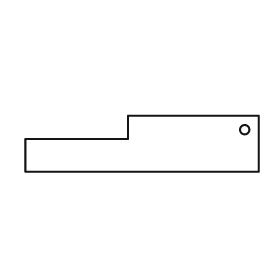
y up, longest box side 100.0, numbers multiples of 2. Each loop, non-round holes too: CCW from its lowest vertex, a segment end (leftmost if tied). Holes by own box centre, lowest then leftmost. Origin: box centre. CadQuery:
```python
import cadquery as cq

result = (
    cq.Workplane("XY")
    .moveTo(-50.0, -12.0)
    .lineTo(50.0, -12.0)
    .lineTo(50.0, 12.0)
    .lineTo(-6.0, 12.0)
    .lineTo(-6.0, 2.0)
    .lineTo(-50.0, 2.0)
    .close()
    .moveTo(44.0, 6.0)
    .circle(2.0)
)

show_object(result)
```